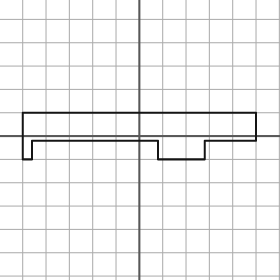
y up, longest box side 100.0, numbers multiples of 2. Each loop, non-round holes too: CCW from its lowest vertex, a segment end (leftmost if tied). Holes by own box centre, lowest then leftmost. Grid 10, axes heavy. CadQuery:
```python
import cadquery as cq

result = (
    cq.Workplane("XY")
    .moveTo(-50.0, -10.0)
    .lineTo(-46.0, -10.0)
    .lineTo(-46.0, -2.0)
    .lineTo(8.0, -2.0)
    .lineTo(8.0, -10.0)
    .lineTo(28.0, -10.0)
    .lineTo(28.0, -2.0)
    .lineTo(50.0, -2.0)
    .lineTo(50.0, 10.0)
    .lineTo(-50.0, 10.0)
    .close()
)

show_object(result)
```